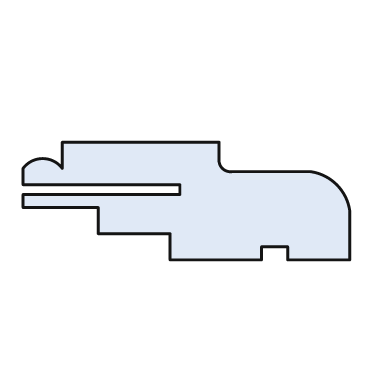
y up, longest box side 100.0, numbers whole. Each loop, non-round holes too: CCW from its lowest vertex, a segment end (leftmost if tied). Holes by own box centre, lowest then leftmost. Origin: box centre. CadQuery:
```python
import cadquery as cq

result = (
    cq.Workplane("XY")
    .moveTo(-5.0, -18.0)
    .lineTo(23.0, -18.0)
    .lineTo(23.0, -14.0)
    .lineTo(31.0, -14.0)
    .lineTo(31.0, -18.0)
    .lineTo(50.0, -18.0)
    .lineTo(50.0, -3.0)
    .threePointArc((46.0, 5.0), (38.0, 9.0))
    .lineTo(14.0, 9.0)
    .threePointArc((11.0, 10.0), (10.0, 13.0))
    .lineTo(10.0, 18.0)
    .lineTo(-38.0, 18.0)
    .lineTo(-38.0, 10.0)
    .threePointArc((-44.0, 13.0), (-50.0, 10.0))
    .lineTo(-50.0, 5.0)
    .lineTo(-2.0, 5.0)
    .lineTo(-2.0, 2.0)
    .lineTo(-50.0, 2.0)
    .lineTo(-50.0, -2.0)
    .lineTo(-27.0, -2.0)
    .lineTo(-27.0, -10.0)
    .lineTo(-5.0, -10.0)
    .close()
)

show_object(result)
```